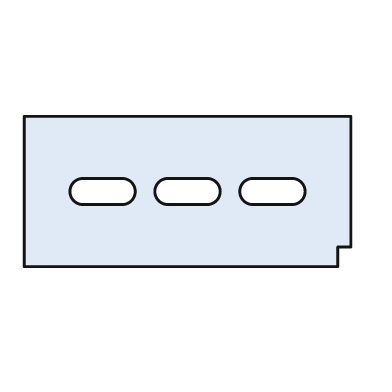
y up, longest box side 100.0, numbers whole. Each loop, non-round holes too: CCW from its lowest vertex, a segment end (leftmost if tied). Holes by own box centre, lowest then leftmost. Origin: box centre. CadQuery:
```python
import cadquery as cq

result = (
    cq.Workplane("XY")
    .moveTo(-50.0, -23.0)
    .lineTo(46.0, -23.0)
    .lineTo(46.0, -17.0)
    .lineTo(50.0, -17.0)
    .lineTo(50.0, 23.0)
    .lineTo(-50.0, 23.0)
    .close()
    .moveTo(-32.0, -4.0)
    .lineTo(-20.0, -4.0)
    .threePointArc((-16.0, 0.0), (-20.0, 4.0))
    .lineTo(-32.0, 4.0)
    .threePointArc((-36.0, 0.0), (-32.0, -4.0))
    .close()
    .moveTo(-6.0, -4.0)
    .lineTo(6.0, -4.0)
    .threePointArc((10.0, 0.0), (6.0, 4.0))
    .lineTo(-6.0, 4.0)
    .threePointArc((-10.0, 0.0), (-6.0, -4.0))
    .close()
    .moveTo(20.0, -4.0)
    .lineTo(32.0, -4.0)
    .threePointArc((36.0, 0.0), (32.0, 4.0))
    .lineTo(20.0, 4.0)
    .threePointArc((16.0, 0.0), (20.0, -4.0))
    .close()
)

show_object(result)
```